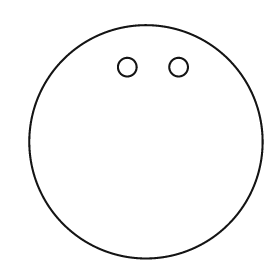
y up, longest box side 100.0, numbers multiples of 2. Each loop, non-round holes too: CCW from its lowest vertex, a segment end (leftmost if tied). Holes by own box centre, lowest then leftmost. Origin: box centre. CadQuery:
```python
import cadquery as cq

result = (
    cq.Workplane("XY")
    .moveTo(0.0, 0.0)
    .circle(50.0)
    .moveTo(-8.0, 32.0)
    .circle(4.0)
    .moveTo(14.0, 32.0)
    .circle(4.0)
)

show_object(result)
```